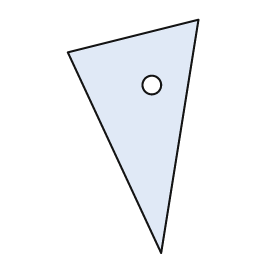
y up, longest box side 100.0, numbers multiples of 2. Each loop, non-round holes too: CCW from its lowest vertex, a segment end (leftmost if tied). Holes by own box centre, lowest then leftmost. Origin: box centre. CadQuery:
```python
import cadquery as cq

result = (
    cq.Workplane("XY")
    .moveTo(12.0, -50.0)
    .lineTo(28.0, 50.0)
    .lineTo(-28.0, 36.0)
    .close()
    .moveTo(8.0, 22.0)
    .circle(4.0)
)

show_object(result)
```